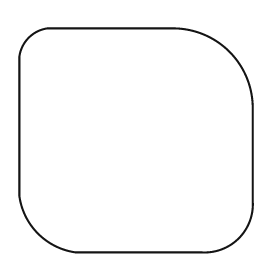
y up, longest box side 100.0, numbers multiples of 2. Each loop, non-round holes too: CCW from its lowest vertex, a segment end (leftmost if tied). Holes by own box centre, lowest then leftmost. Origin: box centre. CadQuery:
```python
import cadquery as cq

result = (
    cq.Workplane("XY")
    .moveTo(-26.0, -48.0)
    .lineTo(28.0, -48.0)
    .threePointArc((44.0, -42.0), (50.0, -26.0))
    .lineTo(50.0, 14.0)
    .threePointArc((40.0, 38.0), (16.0, 48.0))
    .lineTo(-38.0, 48.0)
    .threePointArc((-46.0, 44.0), (-50.0, 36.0))
    .lineTo(-50.0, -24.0)
    .threePointArc((-42.0, -40.0), (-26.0, -48.0))
    .close()
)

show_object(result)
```